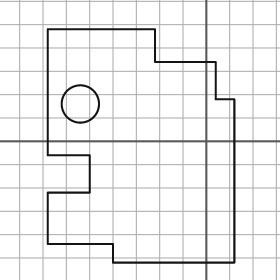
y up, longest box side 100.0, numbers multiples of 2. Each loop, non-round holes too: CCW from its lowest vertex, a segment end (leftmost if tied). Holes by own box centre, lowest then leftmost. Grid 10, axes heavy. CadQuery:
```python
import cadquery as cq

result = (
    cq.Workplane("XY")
    .moveTo(-40.0, -52.0)
    .lineTo(12.0, -52.0)
    .lineTo(12.0, 18.0)
    .lineTo(4.0, 18.0)
    .lineTo(4.0, 34.0)
    .lineTo(-22.0, 34.0)
    .lineTo(-22.0, 48.0)
    .lineTo(-68.0, 48.0)
    .lineTo(-68.0, -6.0)
    .lineTo(-50.0, -6.0)
    .lineTo(-50.0, -22.0)
    .lineTo(-68.0, -22.0)
    .lineTo(-68.0, -44.0)
    .lineTo(-40.0, -44.0)
    .close()
    .moveTo(-54.0, 16.0)
    .circle(8.0)
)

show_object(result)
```